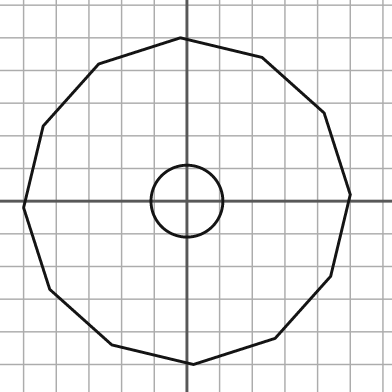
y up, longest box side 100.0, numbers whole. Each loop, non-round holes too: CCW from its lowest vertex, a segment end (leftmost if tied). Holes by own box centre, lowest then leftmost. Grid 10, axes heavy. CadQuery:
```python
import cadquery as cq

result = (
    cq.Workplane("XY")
    .moveTo(2.0, -50.0)
    .lineTo(27.0, -42.0)
    .lineTo(44.0, -23.0)
    .lineTo(50.0, 2.0)
    .lineTo(42.0, 27.0)
    .lineTo(23.0, 44.0)
    .lineTo(-2.0, 50.0)
    .lineTo(-27.0, 42.0)
    .lineTo(-44.0, 23.0)
    .lineTo(-50.0, -2.0)
    .lineTo(-42.0, -27.0)
    .lineTo(-23.0, -44.0)
    .close()
    .moveTo(0.0, 0.0)
    .circle(11.0)
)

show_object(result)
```